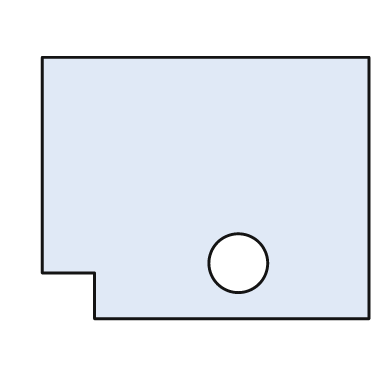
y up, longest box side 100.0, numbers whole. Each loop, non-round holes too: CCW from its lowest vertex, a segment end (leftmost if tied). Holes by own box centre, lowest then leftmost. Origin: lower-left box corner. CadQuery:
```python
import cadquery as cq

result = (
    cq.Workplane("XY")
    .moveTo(16.0, 0.0)
    .lineTo(100.0, 0.0)
    .lineTo(100.0, 80.0)
    .lineTo(0.0, 80.0)
    .lineTo(0.0, 14.0)
    .lineTo(16.0, 14.0)
    .close()
    .moveTo(60.0, 17.0)
    .circle(9.0)
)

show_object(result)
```